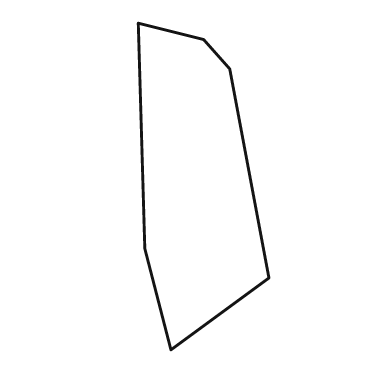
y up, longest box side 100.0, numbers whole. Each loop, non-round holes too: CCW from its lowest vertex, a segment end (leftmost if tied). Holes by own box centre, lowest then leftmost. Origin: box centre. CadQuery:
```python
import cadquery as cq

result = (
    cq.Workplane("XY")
    .moveTo(-10.0, -50.0)
    .lineTo(20.0, -28.0)
    .lineTo(8.0, 36.0)
    .lineTo(0.0, 45.0)
    .lineTo(-20.0, 50.0)
    .lineTo(-18.0, -19.0)
    .close()
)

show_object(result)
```